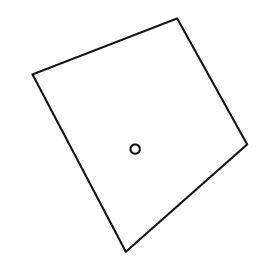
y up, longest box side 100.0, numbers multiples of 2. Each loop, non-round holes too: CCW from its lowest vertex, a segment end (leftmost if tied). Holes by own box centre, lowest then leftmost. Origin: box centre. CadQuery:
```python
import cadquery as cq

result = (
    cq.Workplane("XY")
    .moveTo(-6.0, -50.0)
    .lineTo(46.0, -4.0)
    .lineTo(16.0, 50.0)
    .lineTo(-46.0, 26.0)
    .close()
    .moveTo(-2.0, -6.0)
    .circle(2.0)
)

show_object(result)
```